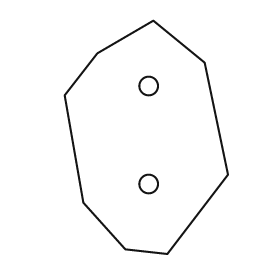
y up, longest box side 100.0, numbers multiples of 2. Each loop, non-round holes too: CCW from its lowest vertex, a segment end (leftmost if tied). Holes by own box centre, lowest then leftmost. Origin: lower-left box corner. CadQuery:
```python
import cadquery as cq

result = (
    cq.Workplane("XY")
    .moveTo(44.0, 0.0)
    .lineTo(70.0, 34.0)
    .lineTo(60.0, 82.0)
    .lineTo(38.0, 100.0)
    .lineTo(14.0, 86.0)
    .lineTo(0.0, 68.0)
    .lineTo(8.0, 22.0)
    .lineTo(26.0, 2.0)
    .close()
    .moveTo(36.0, 30.0)
    .circle(4.0)
    .moveTo(36.0, 72.0)
    .circle(4.0)
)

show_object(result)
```